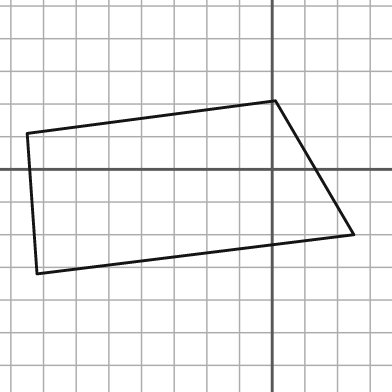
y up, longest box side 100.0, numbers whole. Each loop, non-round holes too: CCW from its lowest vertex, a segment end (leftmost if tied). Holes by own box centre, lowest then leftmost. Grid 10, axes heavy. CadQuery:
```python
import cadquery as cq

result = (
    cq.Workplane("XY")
    .moveTo(-72.0, -32.0)
    .lineTo(25.0, -20.0)
    .lineTo(1.0, 21.0)
    .lineTo(-75.0, 11.0)
    .close()
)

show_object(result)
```